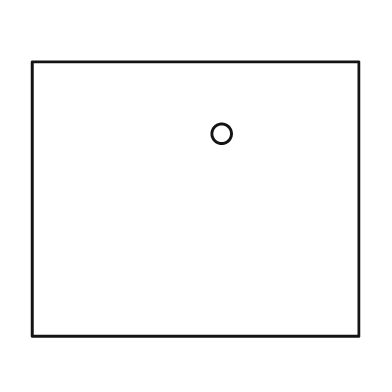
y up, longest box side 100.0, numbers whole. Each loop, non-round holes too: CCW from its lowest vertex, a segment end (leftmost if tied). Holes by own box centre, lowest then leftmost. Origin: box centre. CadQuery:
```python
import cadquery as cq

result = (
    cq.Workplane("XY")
    .moveTo(-50.0, -42.0)
    .lineTo(50.0, -42.0)
    .lineTo(50.0, 42.0)
    .lineTo(-50.0, 42.0)
    .close()
    .moveTo(8.0, 20.0)
    .circle(3.0)
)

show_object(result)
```